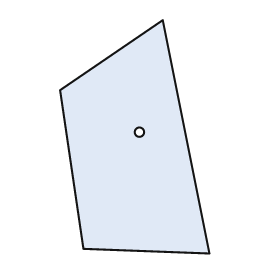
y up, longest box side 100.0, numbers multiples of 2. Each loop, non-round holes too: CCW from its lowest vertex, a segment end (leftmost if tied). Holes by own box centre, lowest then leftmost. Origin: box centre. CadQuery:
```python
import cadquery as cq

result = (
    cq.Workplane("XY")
    .moveTo(32.0, -50.0)
    .lineTo(12.0, 50.0)
    .lineTo(-32.0, 20.0)
    .lineTo(-22.0, -48.0)
    .close()
    .moveTo(2.0, 2.0)
    .circle(2.0)
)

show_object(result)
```